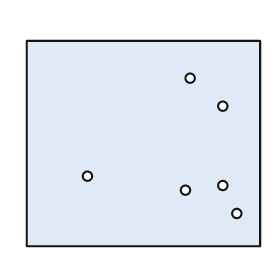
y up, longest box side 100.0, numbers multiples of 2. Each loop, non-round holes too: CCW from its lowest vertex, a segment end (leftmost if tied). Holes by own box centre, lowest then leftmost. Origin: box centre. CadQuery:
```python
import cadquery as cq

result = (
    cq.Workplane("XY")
    .moveTo(-50.0, -44.0)
    .lineTo(50.0, -44.0)
    .lineTo(50.0, 44.0)
    .lineTo(-50.0, 44.0)
    .close()
    .moveTo(40.0, -30.0)
    .circle(2.0)
    .moveTo(18.0, -20.0)
    .circle(2.0)
    .moveTo(34.0, -18.0)
    .circle(2.0)
    .moveTo(-24.0, -14.0)
    .circle(2.0)
    .moveTo(34.0, 16.0)
    .circle(2.0)
    .moveTo(20.0, 28.0)
    .circle(2.0)
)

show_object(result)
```